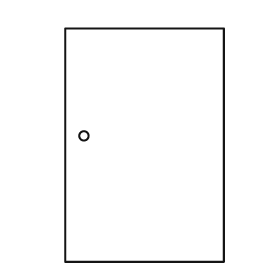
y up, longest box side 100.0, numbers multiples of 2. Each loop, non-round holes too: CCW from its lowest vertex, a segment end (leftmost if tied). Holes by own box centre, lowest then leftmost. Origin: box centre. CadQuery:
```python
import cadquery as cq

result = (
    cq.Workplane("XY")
    .moveTo(-34.0, -50.0)
    .lineTo(34.0, -50.0)
    .lineTo(34.0, 50.0)
    .lineTo(-34.0, 50.0)
    .close()
    .moveTo(-26.0, 4.0)
    .circle(2.0)
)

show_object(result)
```